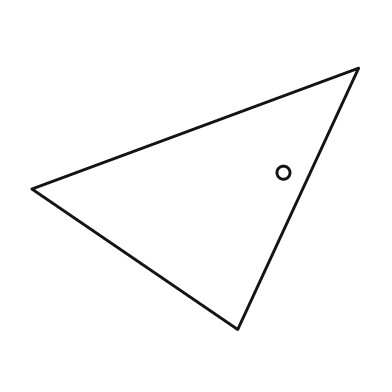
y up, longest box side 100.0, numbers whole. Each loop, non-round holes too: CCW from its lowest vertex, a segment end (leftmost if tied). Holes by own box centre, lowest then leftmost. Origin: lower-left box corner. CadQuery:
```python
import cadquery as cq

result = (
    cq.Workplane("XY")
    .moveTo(63.0, 0.0)
    .lineTo(100.0, 80.0)
    .lineTo(0.0, 43.0)
    .close()
    .moveTo(77.0, 48.0)
    .circle(2.0)
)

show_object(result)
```